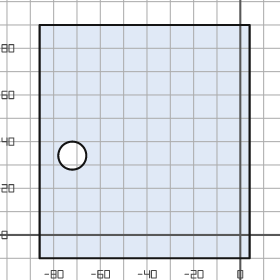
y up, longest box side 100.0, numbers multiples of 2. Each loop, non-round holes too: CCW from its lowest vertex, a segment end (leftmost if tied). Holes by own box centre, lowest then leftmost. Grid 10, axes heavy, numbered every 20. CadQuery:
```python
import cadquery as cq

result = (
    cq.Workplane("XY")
    .moveTo(-86.0, -10.0)
    .lineTo(4.0, -10.0)
    .lineTo(4.0, 90.0)
    .lineTo(-86.0, 90.0)
    .close()
    .moveTo(-72.0, 34.0)
    .circle(6.0)
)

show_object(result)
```